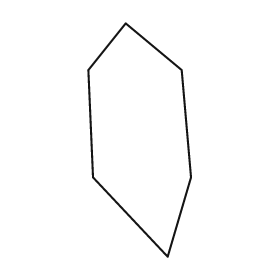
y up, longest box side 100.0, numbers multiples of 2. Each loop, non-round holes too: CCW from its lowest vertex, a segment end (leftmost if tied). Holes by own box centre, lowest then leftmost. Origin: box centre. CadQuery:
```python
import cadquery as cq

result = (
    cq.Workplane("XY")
    .moveTo(12.0, -50.0)
    .lineTo(22.0, -16.0)
    .lineTo(18.0, 30.0)
    .lineTo(-6.0, 50.0)
    .lineTo(-22.0, 30.0)
    .lineTo(-20.0, -16.0)
    .close()
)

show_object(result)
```